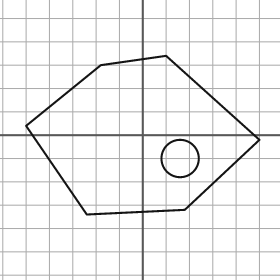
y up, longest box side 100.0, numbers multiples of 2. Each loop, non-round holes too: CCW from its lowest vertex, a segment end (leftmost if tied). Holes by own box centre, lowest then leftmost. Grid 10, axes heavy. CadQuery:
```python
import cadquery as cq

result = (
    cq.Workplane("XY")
    .moveTo(-24.0, -34.0)
    .lineTo(18.0, -32.0)
    .lineTo(50.0, -2.0)
    .lineTo(10.0, 34.0)
    .lineTo(-18.0, 30.0)
    .lineTo(-50.0, 4.0)
    .close()
    .moveTo(16.0, -10.0)
    .circle(8.0)
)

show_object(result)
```